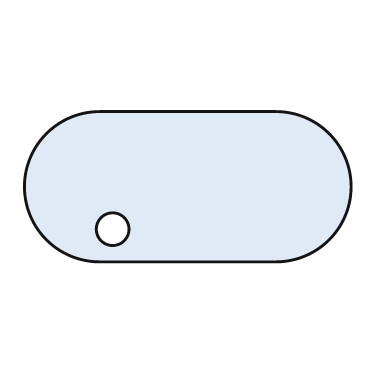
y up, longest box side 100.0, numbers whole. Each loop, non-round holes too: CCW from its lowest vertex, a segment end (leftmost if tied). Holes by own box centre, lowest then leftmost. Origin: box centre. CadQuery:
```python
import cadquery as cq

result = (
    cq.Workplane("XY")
    .moveTo(-27.0, -23.0)
    .lineTo(27.0, -23.0)
    .threePointArc((50.0, 0.0), (27.0, 23.0))
    .lineTo(-27.0, 23.0)
    .threePointArc((-50.0, 0.0), (-27.0, -23.0))
    .close()
    .moveTo(-23.0, -13.0)
    .circle(5.0)
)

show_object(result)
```